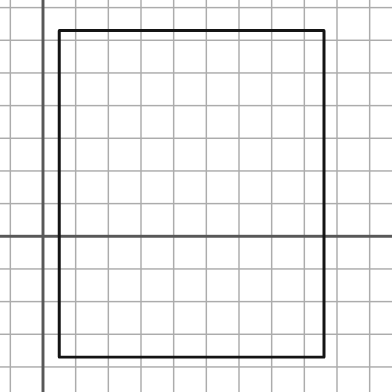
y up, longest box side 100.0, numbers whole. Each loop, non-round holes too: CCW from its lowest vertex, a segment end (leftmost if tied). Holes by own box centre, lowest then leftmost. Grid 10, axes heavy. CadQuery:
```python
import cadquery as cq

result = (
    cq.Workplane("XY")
    .moveTo(5.0, -37.0)
    .lineTo(86.0, -37.0)
    .lineTo(86.0, 63.0)
    .lineTo(5.0, 63.0)
    .close()
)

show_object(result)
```